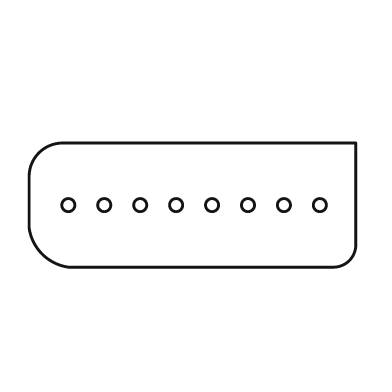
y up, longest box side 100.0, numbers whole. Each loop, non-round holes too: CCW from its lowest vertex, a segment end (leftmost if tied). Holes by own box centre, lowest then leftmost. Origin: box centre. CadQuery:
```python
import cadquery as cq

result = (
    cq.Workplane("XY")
    .moveTo(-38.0, -19.0)
    .lineTo(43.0, -19.0)
    .threePointArc((48.0, -17.0), (50.0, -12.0))
    .lineTo(50.0, 19.0)
    .lineTo(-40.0, 19.0)
    .threePointArc((-47.0, 16.0), (-50.0, 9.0))
    .lineTo(-50.0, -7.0)
    .threePointArc((-46.0, -15.0), (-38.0, -19.0))
    .close()
    .moveTo(-38.0, 0.0)
    .circle(2.0)
    .moveTo(-27.0, 0.0)
    .circle(2.0)
    .moveTo(-16.0, 0.0)
    .circle(2.0)
    .moveTo(-5.0, 0.0)
    .circle(2.0)
    .moveTo(6.0, 0.0)
    .circle(2.0)
    .moveTo(17.0, 0.0)
    .circle(2.0)
    .moveTo(28.0, 0.0)
    .circle(2.0)
    .moveTo(39.0, 0.0)
    .circle(2.0)
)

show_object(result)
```